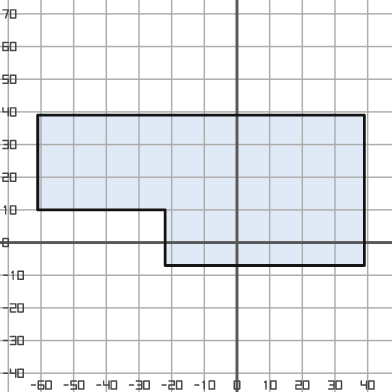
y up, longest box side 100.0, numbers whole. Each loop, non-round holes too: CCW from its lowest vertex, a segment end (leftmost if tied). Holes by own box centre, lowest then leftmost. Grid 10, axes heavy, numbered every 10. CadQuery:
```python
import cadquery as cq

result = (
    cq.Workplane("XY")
    .moveTo(-22.0, -7.0)
    .lineTo(39.0, -7.0)
    .lineTo(39.0, 39.0)
    .lineTo(-61.0, 39.0)
    .lineTo(-61.0, 10.0)
    .lineTo(-22.0, 10.0)
    .close()
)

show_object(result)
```